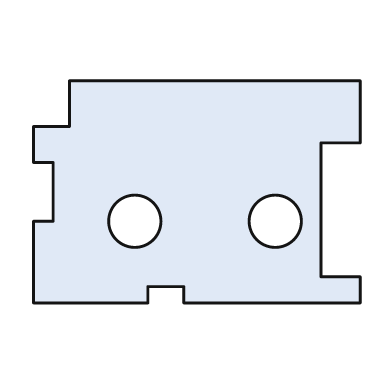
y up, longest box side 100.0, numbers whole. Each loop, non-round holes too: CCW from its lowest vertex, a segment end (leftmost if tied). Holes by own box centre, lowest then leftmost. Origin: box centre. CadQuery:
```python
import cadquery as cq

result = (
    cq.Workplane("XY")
    .moveTo(-50.0, -34.0)
    .lineTo(-15.0, -34.0)
    .lineTo(-15.0, -29.0)
    .lineTo(-4.0, -29.0)
    .lineTo(-4.0, -34.0)
    .lineTo(50.0, -34.0)
    .lineTo(50.0, -26.0)
    .lineTo(38.0, -26.0)
    .lineTo(38.0, 15.0)
    .lineTo(50.0, 15.0)
    .lineTo(50.0, 34.0)
    .lineTo(-39.0, 34.0)
    .lineTo(-39.0, 20.0)
    .lineTo(-50.0, 20.0)
    .lineTo(-50.0, 9.0)
    .lineTo(-44.0, 9.0)
    .lineTo(-44.0, -9.0)
    .lineTo(-50.0, -9.0)
    .close()
    .moveTo(-19.0, -9.0)
    .circle(8.0)
    .moveTo(24.0, -9.0)
    .circle(8.0)
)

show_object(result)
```